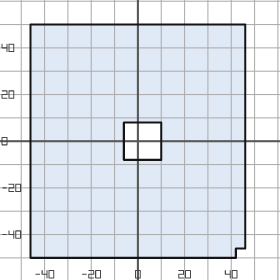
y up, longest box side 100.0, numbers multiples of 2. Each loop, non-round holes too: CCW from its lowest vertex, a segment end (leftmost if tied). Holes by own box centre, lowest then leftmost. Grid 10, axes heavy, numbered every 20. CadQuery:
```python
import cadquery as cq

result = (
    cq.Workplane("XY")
    .moveTo(-46.0, -50.0)
    .lineTo(42.0, -50.0)
    .lineTo(42.0, -46.0)
    .lineTo(46.0, -46.0)
    .lineTo(46.0, 50.0)
    .lineTo(-46.0, 50.0)
    .close()
    .moveTo(-6.0, -8.0)
    .lineTo(10.0, -8.0)
    .lineTo(10.0, 8.0)
    .lineTo(-6.0, 8.0)
    .close()
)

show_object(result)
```